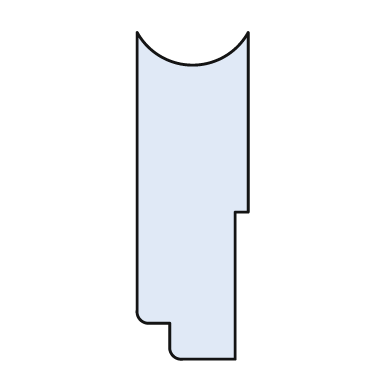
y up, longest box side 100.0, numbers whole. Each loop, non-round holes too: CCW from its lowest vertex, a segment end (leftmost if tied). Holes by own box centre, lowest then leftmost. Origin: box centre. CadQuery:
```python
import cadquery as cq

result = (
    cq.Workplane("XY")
    .moveTo(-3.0, -50.0)
    .lineTo(13.0, -50.0)
    .lineTo(13.0, -5.0)
    .lineTo(17.0, -5.0)
    .lineTo(17.0, 50.0)
    .threePointArc((0.0, 40.0), (-17.0, 50.0))
    .lineTo(-17.0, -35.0)
    .threePointArc((-16.0, -38.0), (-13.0, -39.0))
    .lineTo(-7.0, -39.0)
    .lineTo(-7.0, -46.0)
    .threePointArc((-6.0, -49.0), (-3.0, -50.0))
    .close()
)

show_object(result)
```